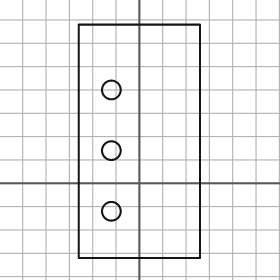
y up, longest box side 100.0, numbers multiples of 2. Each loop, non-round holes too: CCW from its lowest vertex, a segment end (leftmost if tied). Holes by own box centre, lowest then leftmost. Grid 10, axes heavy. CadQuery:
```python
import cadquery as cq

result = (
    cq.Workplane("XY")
    .moveTo(-26.0, -32.0)
    .lineTo(26.0, -32.0)
    .lineTo(26.0, 68.0)
    .lineTo(-26.0, 68.0)
    .close()
    .moveTo(-12.0, -12.0)
    .circle(4.0)
    .moveTo(-12.0, 14.0)
    .circle(4.0)
    .moveTo(-12.0, 40.0)
    .circle(4.0)
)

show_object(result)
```